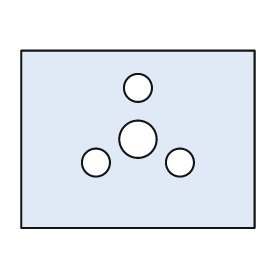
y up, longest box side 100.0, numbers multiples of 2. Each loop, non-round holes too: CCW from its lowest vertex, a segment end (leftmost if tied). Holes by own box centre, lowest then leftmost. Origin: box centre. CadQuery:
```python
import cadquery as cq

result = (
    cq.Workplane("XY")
    .moveTo(-50.0, -38.0)
    .lineTo(50.0, -38.0)
    .lineTo(50.0, 38.0)
    .lineTo(-50.0, 38.0)
    .close()
    .moveTo(-18.0, -10.0)
    .circle(6.0)
    .moveTo(18.0, -10.0)
    .circle(6.0)
    .moveTo(0.0, 0.0)
    .circle(8.0)
    .moveTo(0.0, 22.0)
    .circle(6.0)
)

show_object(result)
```